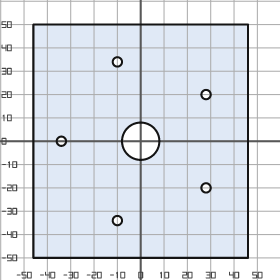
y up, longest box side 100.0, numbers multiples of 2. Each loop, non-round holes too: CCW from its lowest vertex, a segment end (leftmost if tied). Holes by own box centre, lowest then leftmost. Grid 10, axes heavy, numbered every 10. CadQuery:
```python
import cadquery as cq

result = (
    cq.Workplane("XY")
    .moveTo(-46.0, -50.0)
    .lineTo(46.0, -50.0)
    .lineTo(46.0, 50.0)
    .lineTo(-46.0, 50.0)
    .close()
    .moveTo(-10.0, -34.0)
    .circle(2.0)
    .moveTo(28.0, -20.0)
    .circle(2.0)
    .moveTo(-34.0, 0.0)
    .circle(2.0)
    .moveTo(0.0, 0.0)
    .circle(8.0)
    .moveTo(28.0, 20.0)
    .circle(2.0)
    .moveTo(-10.0, 34.0)
    .circle(2.0)
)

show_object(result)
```